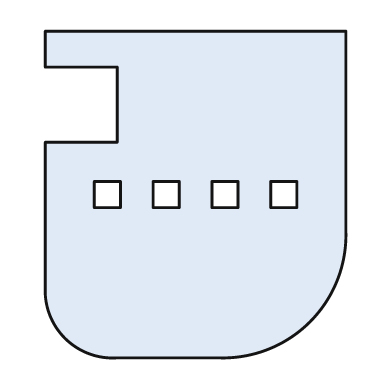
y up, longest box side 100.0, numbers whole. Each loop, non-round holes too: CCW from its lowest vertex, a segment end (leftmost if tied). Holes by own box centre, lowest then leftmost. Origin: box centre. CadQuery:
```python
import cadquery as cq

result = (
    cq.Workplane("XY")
    .moveTo(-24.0, -50.0)
    .lineTo(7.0, -50.0)
    .threePointArc((35.0, -39.0), (46.0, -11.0))
    .lineTo(46.0, 50.0)
    .lineTo(-46.0, 50.0)
    .lineTo(-46.0, 39.0)
    .lineTo(-24.0, 39.0)
    .lineTo(-24.0, 16.0)
    .lineTo(-46.0, 16.0)
    .lineTo(-46.0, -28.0)
    .threePointArc((-40.0, -44.0), (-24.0, -50.0))
    .close()
    .moveTo(-31.0, -4.0)
    .lineTo(-23.0, -4.0)
    .lineTo(-23.0, 4.0)
    .lineTo(-31.0, 4.0)
    .close()
    .moveTo(-13.0, -4.0)
    .lineTo(-5.0, -4.0)
    .lineTo(-5.0, 4.0)
    .lineTo(-13.0, 4.0)
    .close()
    .moveTo(5.0, -4.0)
    .lineTo(13.0, -4.0)
    .lineTo(13.0, 4.0)
    .lineTo(5.0, 4.0)
    .close()
    .moveTo(23.0, -4.0)
    .lineTo(31.0, -4.0)
    .lineTo(31.0, 4.0)
    .lineTo(23.0, 4.0)
    .close()
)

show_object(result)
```